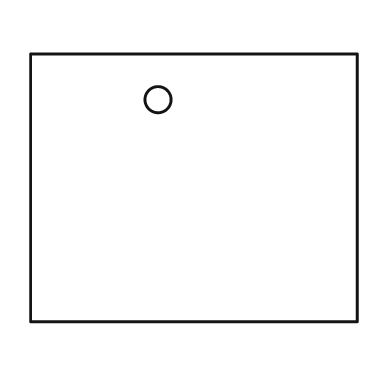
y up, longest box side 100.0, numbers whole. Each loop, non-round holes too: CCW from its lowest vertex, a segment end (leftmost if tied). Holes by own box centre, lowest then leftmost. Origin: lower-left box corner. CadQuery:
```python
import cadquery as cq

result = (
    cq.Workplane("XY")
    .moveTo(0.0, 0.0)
    .lineTo(100.0, 0.0)
    .lineTo(100.0, 82.0)
    .lineTo(0.0, 82.0)
    .close()
    .moveTo(39.0, 68.0)
    .circle(4.0)
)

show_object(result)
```